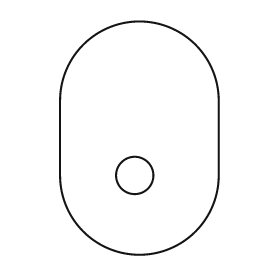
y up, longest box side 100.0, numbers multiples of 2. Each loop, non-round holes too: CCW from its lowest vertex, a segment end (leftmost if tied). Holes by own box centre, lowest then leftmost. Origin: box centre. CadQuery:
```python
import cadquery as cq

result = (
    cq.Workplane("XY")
    .moveTo(-34.0, -16.0)
    .threePointArc((0.0, -50.0), (34.0, -16.0))
    .lineTo(34.0, 16.0)
    .threePointArc((0.0, 50.0), (-34.0, 16.0))
    .close()
    .moveTo(-2.0, -16.0)
    .circle(8.0)
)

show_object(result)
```